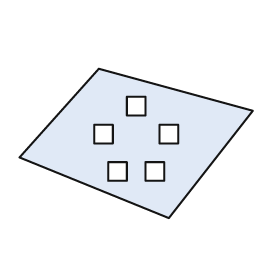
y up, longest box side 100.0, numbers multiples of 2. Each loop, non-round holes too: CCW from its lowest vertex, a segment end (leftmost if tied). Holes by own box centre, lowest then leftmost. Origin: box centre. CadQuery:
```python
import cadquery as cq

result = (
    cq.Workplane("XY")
    .moveTo(14.0, -32.0)
    .lineTo(50.0, 14.0)
    .lineTo(-16.0, 32.0)
    .lineTo(-50.0, -6.0)
    .close()
    .moveTo(-12.0, -16.0)
    .lineTo(-4.0, -16.0)
    .lineTo(-4.0, -8.0)
    .lineTo(-12.0, -8.0)
    .close()
    .moveTo(4.0, -16.0)
    .lineTo(12.0, -16.0)
    .lineTo(12.0, -8.0)
    .lineTo(4.0, -8.0)
    .close()
    .moveTo(-18.0, 0.0)
    .lineTo(-10.0, 0.0)
    .lineTo(-10.0, 8.0)
    .lineTo(-18.0, 8.0)
    .close()
    .moveTo(10.0, 0.0)
    .lineTo(18.0, 0.0)
    .lineTo(18.0, 8.0)
    .lineTo(10.0, 8.0)
    .close()
    .moveTo(-4.0, 12.0)
    .lineTo(4.0, 12.0)
    .lineTo(4.0, 20.0)
    .lineTo(-4.0, 20.0)
    .close()
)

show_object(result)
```